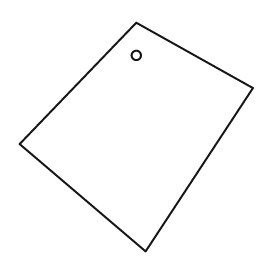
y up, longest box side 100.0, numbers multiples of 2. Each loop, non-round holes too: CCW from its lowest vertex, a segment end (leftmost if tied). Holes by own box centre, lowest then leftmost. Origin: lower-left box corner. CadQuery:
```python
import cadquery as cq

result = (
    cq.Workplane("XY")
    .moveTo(54.0, 0.0)
    .lineTo(100.0, 70.0)
    .lineTo(50.0, 98.0)
    .lineTo(0.0, 46.0)
    .close()
    .moveTo(50.0, 84.0)
    .circle(2.0)
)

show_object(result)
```